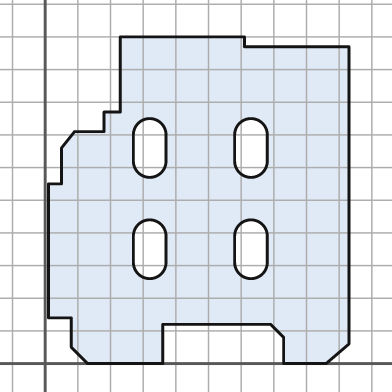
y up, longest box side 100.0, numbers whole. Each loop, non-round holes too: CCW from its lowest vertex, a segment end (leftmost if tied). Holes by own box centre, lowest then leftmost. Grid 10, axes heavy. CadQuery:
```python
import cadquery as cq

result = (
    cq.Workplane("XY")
    .moveTo(13.0, 0.0)
    .lineTo(36.0, 0.0)
    .lineTo(36.0, 12.0)
    .lineTo(69.0, 12.0)
    .lineTo(73.0, 8.0)
    .lineTo(73.0, 0.0)
    .lineTo(86.0, 0.0)
    .lineTo(93.0, 6.0)
    .lineTo(93.0, 97.0)
    .lineTo(61.0, 97.0)
    .lineTo(61.0, 100.0)
    .lineTo(23.0, 100.0)
    .lineTo(23.0, 77.0)
    .lineTo(18.0, 77.0)
    .lineTo(18.0, 71.0)
    .lineTo(9.0, 71.0)
    .lineTo(5.0, 66.0)
    .lineTo(5.0, 55.0)
    .lineTo(1.0, 55.0)
    .lineTo(1.0, 14.0)
    .lineTo(8.0, 14.0)
    .lineTo(8.0, 5.0)
    .close()
    .moveTo(27.0, 31.0)
    .threePointArc((32.0, 26.0), (37.0, 31.0))
    .lineTo(37.0, 39.0)
    .threePointArc((32.0, 44.0), (27.0, 39.0))
    .close()
    .moveTo(58.0, 31.0)
    .threePointArc((63.0, 26.0), (68.0, 31.0))
    .lineTo(68.0, 39.0)
    .threePointArc((63.0, 44.0), (58.0, 39.0))
    .close()
    .moveTo(27.0, 62.0)
    .threePointArc((32.0, 57.0), (37.0, 62.0))
    .lineTo(37.0, 70.0)
    .threePointArc((32.0, 75.0), (27.0, 70.0))
    .close()
    .moveTo(58.0, 62.0)
    .threePointArc((63.0, 57.0), (68.0, 62.0))
    .lineTo(68.0, 70.0)
    .threePointArc((63.0, 75.0), (58.0, 70.0))
    .close()
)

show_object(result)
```